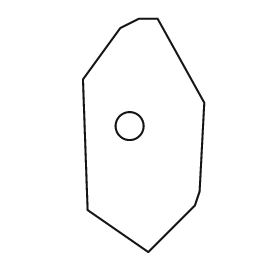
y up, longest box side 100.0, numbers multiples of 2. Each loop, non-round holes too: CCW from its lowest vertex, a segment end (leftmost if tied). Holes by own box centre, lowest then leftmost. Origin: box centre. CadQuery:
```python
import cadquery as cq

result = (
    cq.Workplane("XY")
    .moveTo(2.0, -50.0)
    .lineTo(22.0, -30.0)
    .lineTo(24.0, -24.0)
    .lineTo(26.0, 14.0)
    .lineTo(6.0, 50.0)
    .lineTo(-2.0, 50.0)
    .lineTo(-10.0, 46.0)
    .lineTo(-26.0, 24.0)
    .lineTo(-24.0, -32.0)
    .close()
    .moveTo(-6.0, 4.0)
    .circle(6.0)
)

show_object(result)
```